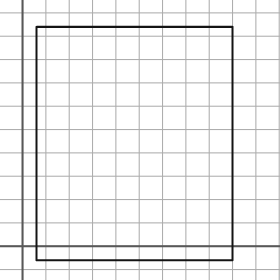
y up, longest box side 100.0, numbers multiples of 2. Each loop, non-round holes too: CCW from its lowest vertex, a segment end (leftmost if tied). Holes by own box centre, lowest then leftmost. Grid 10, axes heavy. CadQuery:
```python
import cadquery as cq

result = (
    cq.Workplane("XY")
    .moveTo(6.0, -6.0)
    .lineTo(90.0, -6.0)
    .lineTo(90.0, 94.0)
    .lineTo(6.0, 94.0)
    .close()
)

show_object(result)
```